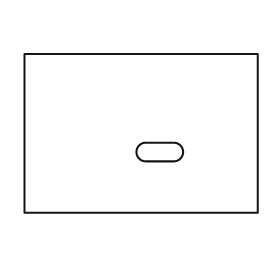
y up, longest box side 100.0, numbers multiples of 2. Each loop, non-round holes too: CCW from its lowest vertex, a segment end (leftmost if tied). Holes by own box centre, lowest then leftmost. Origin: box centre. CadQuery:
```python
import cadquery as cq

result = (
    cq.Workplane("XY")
    .moveTo(-50.0, -34.0)
    .lineTo(50.0, -34.0)
    .lineTo(50.0, 34.0)
    .lineTo(-50.0, 34.0)
    .close()
    .moveTo(2.0, -12.0)
    .lineTo(14.0, -12.0)
    .threePointArc((18.0, -8.0), (14.0, -4.0))
    .lineTo(2.0, -4.0)
    .threePointArc((-2.0, -8.0), (2.0, -12.0))
    .close()
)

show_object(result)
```